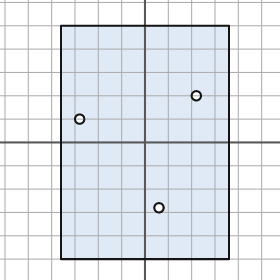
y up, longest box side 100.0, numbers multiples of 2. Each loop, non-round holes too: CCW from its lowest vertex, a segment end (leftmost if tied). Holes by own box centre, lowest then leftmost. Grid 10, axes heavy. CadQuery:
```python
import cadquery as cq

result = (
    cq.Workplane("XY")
    .moveTo(-36.0, -50.0)
    .lineTo(36.0, -50.0)
    .lineTo(36.0, 50.0)
    .lineTo(-36.0, 50.0)
    .close()
    .moveTo(6.0, -28.0)
    .circle(2.0)
    .moveTo(-28.0, 10.0)
    .circle(2.0)
    .moveTo(22.0, 20.0)
    .circle(2.0)
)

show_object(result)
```